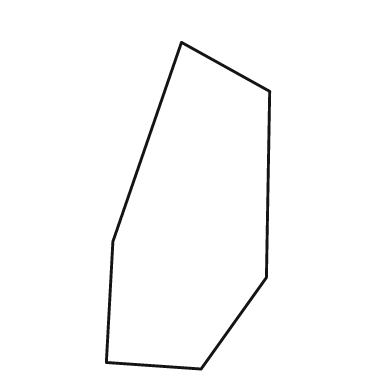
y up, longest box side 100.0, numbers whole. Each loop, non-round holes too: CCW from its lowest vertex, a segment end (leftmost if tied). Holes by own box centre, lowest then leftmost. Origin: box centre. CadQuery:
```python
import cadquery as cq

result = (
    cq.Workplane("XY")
    .moveTo(4.0, -50.0)
    .lineTo(24.0, -22.0)
    .lineTo(25.0, 35.0)
    .lineTo(-2.0, 50.0)
    .lineTo(-23.0, -11.0)
    .lineTo(-25.0, -48.0)
    .close()
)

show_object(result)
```